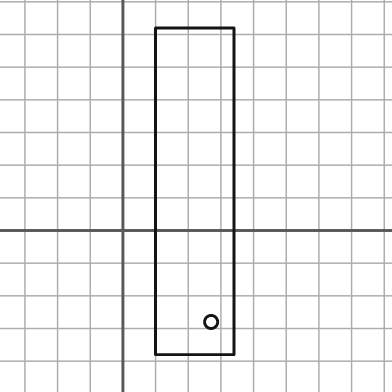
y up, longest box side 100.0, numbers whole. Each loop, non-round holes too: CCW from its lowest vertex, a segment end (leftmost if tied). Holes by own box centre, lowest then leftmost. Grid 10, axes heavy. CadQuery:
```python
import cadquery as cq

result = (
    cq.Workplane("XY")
    .moveTo(10.0, -38.0)
    .lineTo(34.0, -38.0)
    .lineTo(34.0, 62.0)
    .lineTo(10.0, 62.0)
    .close()
    .moveTo(27.0, -28.0)
    .circle(2.0)
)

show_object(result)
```